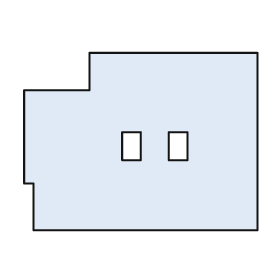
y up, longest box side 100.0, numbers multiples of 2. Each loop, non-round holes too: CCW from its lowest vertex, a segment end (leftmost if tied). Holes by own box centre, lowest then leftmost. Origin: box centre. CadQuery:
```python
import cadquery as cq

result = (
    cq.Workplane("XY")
    .moveTo(-46.0, -38.0)
    .lineTo(50.0, -38.0)
    .lineTo(50.0, 38.0)
    .lineTo(-22.0, 38.0)
    .lineTo(-22.0, 22.0)
    .lineTo(-50.0, 22.0)
    .lineTo(-50.0, -18.0)
    .lineTo(-46.0, -18.0)
    .close()
    .moveTo(-8.0, -8.0)
    .lineTo(0.0, -8.0)
    .lineTo(0.0, 4.0)
    .lineTo(-8.0, 4.0)
    .close()
    .moveTo(12.0, -8.0)
    .lineTo(20.0, -8.0)
    .lineTo(20.0, 4.0)
    .lineTo(12.0, 4.0)
    .close()
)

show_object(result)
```